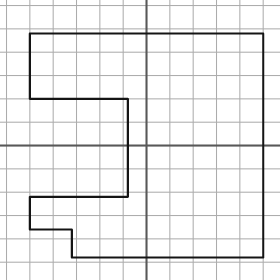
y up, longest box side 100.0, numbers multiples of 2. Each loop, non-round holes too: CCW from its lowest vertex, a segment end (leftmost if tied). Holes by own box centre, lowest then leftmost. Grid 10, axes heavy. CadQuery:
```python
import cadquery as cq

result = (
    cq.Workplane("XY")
    .moveTo(-32.0, -48.0)
    .lineTo(50.0, -48.0)
    .lineTo(50.0, 48.0)
    .lineTo(-50.0, 48.0)
    .lineTo(-50.0, 20.0)
    .lineTo(-8.0, 20.0)
    .lineTo(-8.0, -22.0)
    .lineTo(-50.0, -22.0)
    .lineTo(-50.0, -36.0)
    .lineTo(-32.0, -36.0)
    .close()
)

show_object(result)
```